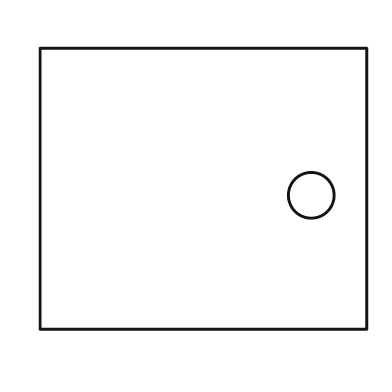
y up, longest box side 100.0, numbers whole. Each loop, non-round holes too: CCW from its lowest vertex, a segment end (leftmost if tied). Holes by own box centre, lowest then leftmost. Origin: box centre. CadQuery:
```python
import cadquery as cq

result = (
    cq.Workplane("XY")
    .moveTo(-50.0, -43.0)
    .lineTo(50.0, -43.0)
    .lineTo(50.0, 43.0)
    .lineTo(-50.0, 43.0)
    .close()
    .moveTo(33.0, -2.0)
    .circle(7.0)
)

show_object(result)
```